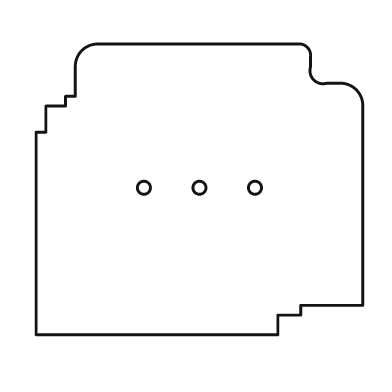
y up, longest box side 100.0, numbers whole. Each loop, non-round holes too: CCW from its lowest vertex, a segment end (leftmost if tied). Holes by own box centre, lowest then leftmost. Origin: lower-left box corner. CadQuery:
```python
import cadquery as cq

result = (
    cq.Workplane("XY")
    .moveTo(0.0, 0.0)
    .lineTo(74.0, 0.0)
    .lineTo(74.0, 6.0)
    .lineTo(81.0, 6.0)
    .lineTo(81.0, 9.0)
    .lineTo(100.0, 9.0)
    .lineTo(100.0, 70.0)
    .threePointArc((98.0, 75.0), (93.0, 77.0))
    .lineTo(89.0, 77.0)
    .threePointArc((85.0, 78.0), (84.0, 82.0))
    .lineTo(84.0, 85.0)
    .threePointArc((83.0, 88.0), (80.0, 89.0))
    .lineTo(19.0, 89.0)
    .threePointArc((14.0, 87.0), (12.0, 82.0))
    .lineTo(12.0, 73.0)
    .lineTo(9.0, 73.0)
    .lineTo(9.0, 70.0)
    .lineTo(3.0, 70.0)
    .lineTo(3.0, 62.0)
    .lineTo(0.0, 62.0)
    .close()
    .moveTo(33.0, 45.0)
    .circle(2.0)
    .moveTo(50.0, 45.0)
    .circle(2.0)
    .moveTo(67.0, 45.0)
    .circle(2.0)
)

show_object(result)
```